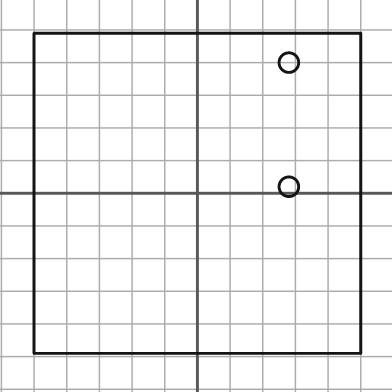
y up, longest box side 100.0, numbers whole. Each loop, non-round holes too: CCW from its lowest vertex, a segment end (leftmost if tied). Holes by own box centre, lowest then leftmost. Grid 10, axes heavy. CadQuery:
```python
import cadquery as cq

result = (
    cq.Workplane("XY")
    .moveTo(-50.0, -49.0)
    .lineTo(50.0, -49.0)
    .lineTo(50.0, 49.0)
    .lineTo(-50.0, 49.0)
    .close()
    .moveTo(28.0, 2.0)
    .circle(3.0)
    .moveTo(28.0, 40.0)
    .circle(3.0)
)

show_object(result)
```